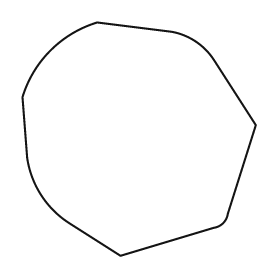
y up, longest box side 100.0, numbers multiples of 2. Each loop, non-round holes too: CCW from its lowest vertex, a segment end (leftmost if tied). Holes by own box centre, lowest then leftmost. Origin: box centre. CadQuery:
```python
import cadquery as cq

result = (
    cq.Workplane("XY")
    .moveTo(-8.0, -50.0)
    .lineTo(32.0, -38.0)
    .threePointArc((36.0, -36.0), (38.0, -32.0))
    .lineTo(50.0, 6.0)
    .lineTo(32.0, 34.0)
    .threePointArc((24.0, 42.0), (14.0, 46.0))
    .lineTo(-18.0, 50.0)
    .threePointArc((-38.0, 38.0), (-50.0, 18.0))
    .lineTo(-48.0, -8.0)
    .threePointArc((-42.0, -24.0), (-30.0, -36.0))
    .close()
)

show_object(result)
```